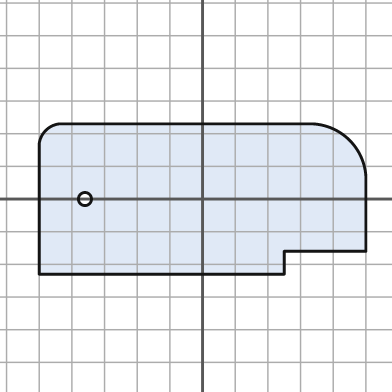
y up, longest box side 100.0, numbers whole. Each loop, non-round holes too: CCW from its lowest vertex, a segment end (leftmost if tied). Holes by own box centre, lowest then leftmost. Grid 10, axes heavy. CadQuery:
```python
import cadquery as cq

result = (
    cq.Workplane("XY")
    .moveTo(-50.0, -23.0)
    .lineTo(25.0, -23.0)
    .lineTo(25.0, -16.0)
    .lineTo(50.0, -16.0)
    .lineTo(50.0, 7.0)
    .threePointArc((45.0, 18.0), (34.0, 23.0))
    .lineTo(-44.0, 23.0)
    .threePointArc((-48.0, 21.0), (-50.0, 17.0))
    .close()
    .moveTo(-36.0, 0.0)
    .circle(2.0)
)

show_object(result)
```